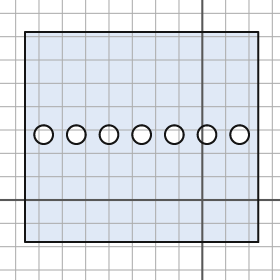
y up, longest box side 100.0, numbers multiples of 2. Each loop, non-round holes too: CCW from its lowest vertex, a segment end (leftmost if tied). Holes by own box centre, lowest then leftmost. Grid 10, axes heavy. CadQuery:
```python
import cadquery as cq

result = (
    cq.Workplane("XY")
    .moveTo(-76.0, -18.0)
    .lineTo(24.0, -18.0)
    .lineTo(24.0, 72.0)
    .lineTo(-76.0, 72.0)
    .close()
    .moveTo(-68.0, 28.0)
    .circle(4.0)
    .moveTo(-54.0, 28.0)
    .circle(4.0)
    .moveTo(-40.0, 28.0)
    .circle(4.0)
    .moveTo(-26.0, 28.0)
    .circle(4.0)
    .moveTo(-12.0, 28.0)
    .circle(4.0)
    .moveTo(2.0, 28.0)
    .circle(4.0)
    .moveTo(16.0, 28.0)
    .circle(4.0)
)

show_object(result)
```